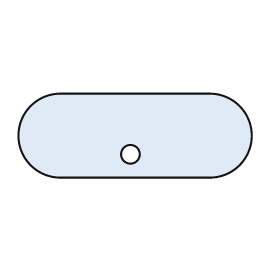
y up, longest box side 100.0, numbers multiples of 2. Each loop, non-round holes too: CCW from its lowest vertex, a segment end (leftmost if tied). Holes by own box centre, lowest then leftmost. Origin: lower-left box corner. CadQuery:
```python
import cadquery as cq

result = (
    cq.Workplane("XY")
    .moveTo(18.0, 0.0)
    .lineTo(82.0, 0.0)
    .threePointArc((100.0, 18.0), (82.0, 36.0))
    .lineTo(18.0, 36.0)
    .threePointArc((0.0, 18.0), (18.0, 0.0))
    .close()
    .moveTo(48.0, 10.0)
    .circle(4.0)
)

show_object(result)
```